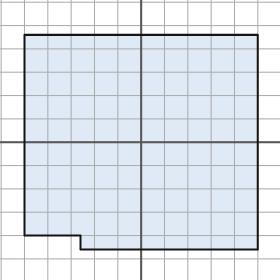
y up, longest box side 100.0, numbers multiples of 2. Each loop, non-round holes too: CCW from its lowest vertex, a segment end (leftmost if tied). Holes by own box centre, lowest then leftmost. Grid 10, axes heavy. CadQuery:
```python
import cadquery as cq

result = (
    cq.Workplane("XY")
    .moveTo(-26.0, -46.0)
    .lineTo(50.0, -46.0)
    .lineTo(50.0, 46.0)
    .lineTo(-50.0, 46.0)
    .lineTo(-50.0, -40.0)
    .lineTo(-26.0, -40.0)
    .close()
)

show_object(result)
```